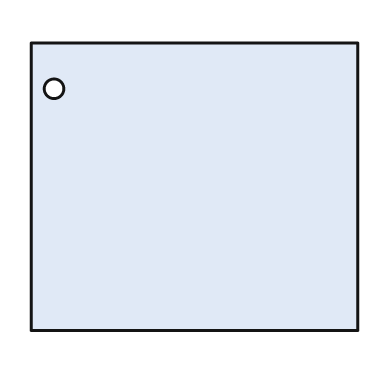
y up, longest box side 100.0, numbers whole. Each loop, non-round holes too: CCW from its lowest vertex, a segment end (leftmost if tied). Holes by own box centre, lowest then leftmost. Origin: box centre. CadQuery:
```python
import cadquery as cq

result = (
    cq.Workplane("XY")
    .moveTo(-50.0, -44.0)
    .lineTo(50.0, -44.0)
    .lineTo(50.0, 44.0)
    .lineTo(-50.0, 44.0)
    .close()
    .moveTo(-43.0, 30.0)
    .circle(3.0)
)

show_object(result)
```